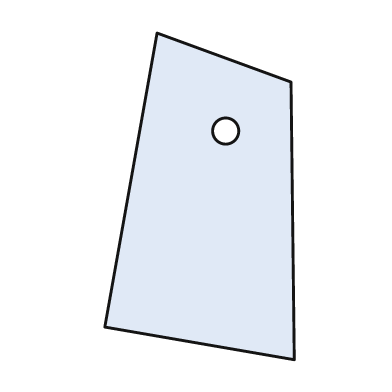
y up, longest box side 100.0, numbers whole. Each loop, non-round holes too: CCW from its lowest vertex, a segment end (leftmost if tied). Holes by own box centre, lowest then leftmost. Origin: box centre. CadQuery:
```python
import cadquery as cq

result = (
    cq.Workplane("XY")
    .moveTo(29.0, -50.0)
    .lineTo(28.0, 35.0)
    .lineTo(-13.0, 50.0)
    .lineTo(-29.0, -40.0)
    .close()
    .moveTo(8.0, 20.0)
    .circle(4.0)
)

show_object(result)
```